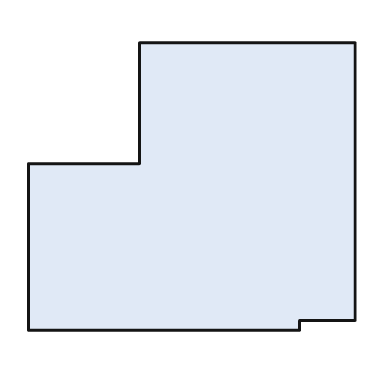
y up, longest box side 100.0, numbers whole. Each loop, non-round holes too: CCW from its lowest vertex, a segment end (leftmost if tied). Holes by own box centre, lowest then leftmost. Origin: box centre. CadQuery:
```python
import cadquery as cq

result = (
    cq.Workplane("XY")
    .moveTo(-50.0, -44.0)
    .lineTo(33.0, -44.0)
    .lineTo(33.0, -41.0)
    .lineTo(50.0, -41.0)
    .lineTo(50.0, 44.0)
    .lineTo(-16.0, 44.0)
    .lineTo(-16.0, 7.0)
    .lineTo(-50.0, 7.0)
    .close()
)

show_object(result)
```